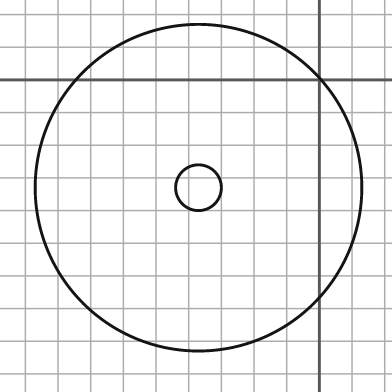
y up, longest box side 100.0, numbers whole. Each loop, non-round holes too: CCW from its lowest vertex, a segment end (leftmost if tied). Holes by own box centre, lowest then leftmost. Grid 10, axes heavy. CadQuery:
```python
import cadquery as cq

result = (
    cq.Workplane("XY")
    .moveTo(-37.0, -33.0)
    .circle(50.0)
    .moveTo(-37.0, -33.0)
    .circle(7.0)
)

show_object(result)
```